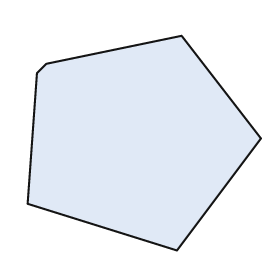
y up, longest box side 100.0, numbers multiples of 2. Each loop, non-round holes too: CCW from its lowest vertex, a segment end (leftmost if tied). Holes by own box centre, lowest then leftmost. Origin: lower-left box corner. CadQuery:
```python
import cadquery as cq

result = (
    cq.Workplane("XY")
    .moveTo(64.0, 0.0)
    .lineTo(100.0, 48.0)
    .lineTo(66.0, 92.0)
    .lineTo(8.0, 80.0)
    .lineTo(4.0, 76.0)
    .lineTo(0.0, 20.0)
    .close()
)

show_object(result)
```